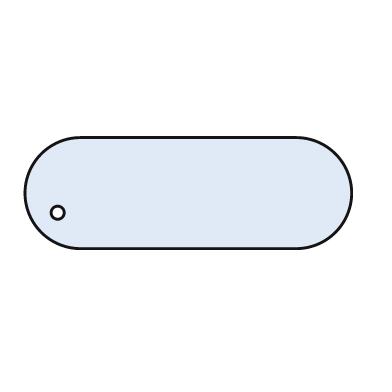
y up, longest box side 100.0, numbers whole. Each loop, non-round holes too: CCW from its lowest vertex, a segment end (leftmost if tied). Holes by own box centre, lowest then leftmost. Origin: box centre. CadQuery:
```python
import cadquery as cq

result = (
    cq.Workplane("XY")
    .moveTo(-33.0, -17.0)
    .lineTo(33.0, -17.0)
    .threePointArc((50.0, 0.0), (33.0, 17.0))
    .lineTo(-33.0, 17.0)
    .threePointArc((-50.0, 0.0), (-33.0, -17.0))
    .close()
    .moveTo(-40.0, -6.0)
    .circle(2.0)
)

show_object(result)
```